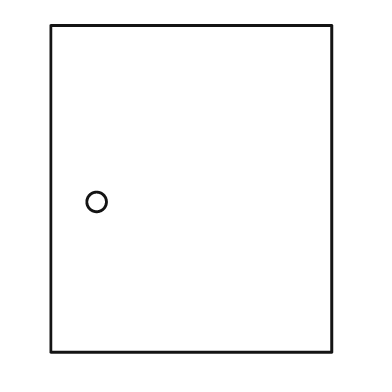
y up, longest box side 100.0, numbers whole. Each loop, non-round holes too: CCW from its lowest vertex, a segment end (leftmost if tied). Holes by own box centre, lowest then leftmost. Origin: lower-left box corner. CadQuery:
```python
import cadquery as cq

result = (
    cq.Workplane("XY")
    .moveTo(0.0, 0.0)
    .lineTo(86.0, 0.0)
    .lineTo(86.0, 100.0)
    .lineTo(0.0, 100.0)
    .close()
    .moveTo(14.0, 46.0)
    .circle(3.0)
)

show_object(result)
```